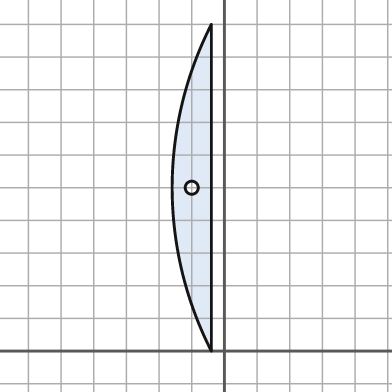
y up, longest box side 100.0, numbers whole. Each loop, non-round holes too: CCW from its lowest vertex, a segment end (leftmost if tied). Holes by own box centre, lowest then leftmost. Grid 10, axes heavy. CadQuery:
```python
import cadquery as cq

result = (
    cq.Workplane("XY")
    .moveTo(-4.0, 0.0)
    .lineTo(-4.0, 100.0)
    .threePointArc((-16.0, 50.0), (-4.0, 0.0))
    .close()
    .moveTo(-10.0, 50.0)
    .circle(2.0)
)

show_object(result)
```